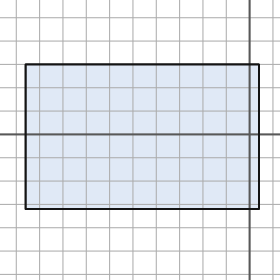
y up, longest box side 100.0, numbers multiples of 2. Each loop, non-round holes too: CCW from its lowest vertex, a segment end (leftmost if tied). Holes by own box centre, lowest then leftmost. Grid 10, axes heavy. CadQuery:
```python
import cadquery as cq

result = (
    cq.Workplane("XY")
    .moveTo(-96.0, -32.0)
    .lineTo(4.0, -32.0)
    .lineTo(4.0, 30.0)
    .lineTo(-96.0, 30.0)
    .close()
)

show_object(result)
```